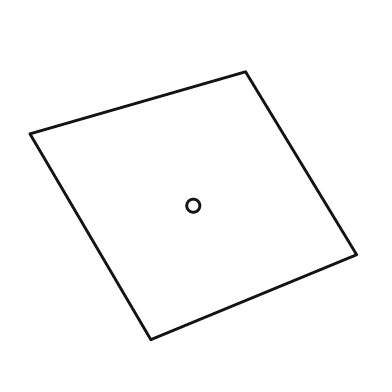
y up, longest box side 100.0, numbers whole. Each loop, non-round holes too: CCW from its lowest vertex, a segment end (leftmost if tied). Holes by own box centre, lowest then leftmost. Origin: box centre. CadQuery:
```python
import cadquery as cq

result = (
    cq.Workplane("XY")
    .moveTo(-13.0, -41.0)
    .lineTo(50.0, -15.0)
    .lineTo(16.0, 41.0)
    .lineTo(-50.0, 22.0)
    .close()
    .moveTo(0.0, 0.0)
    .circle(2.0)
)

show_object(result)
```